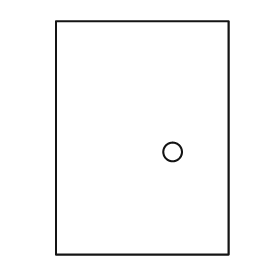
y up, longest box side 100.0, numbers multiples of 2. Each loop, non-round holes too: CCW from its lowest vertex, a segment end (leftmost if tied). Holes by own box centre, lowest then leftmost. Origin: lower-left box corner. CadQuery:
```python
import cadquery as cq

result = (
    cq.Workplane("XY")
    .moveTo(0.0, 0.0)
    .lineTo(74.0, 0.0)
    .lineTo(74.0, 100.0)
    .lineTo(0.0, 100.0)
    .close()
    .moveTo(50.0, 44.0)
    .circle(4.0)
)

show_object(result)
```